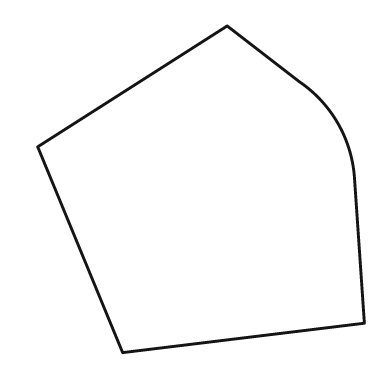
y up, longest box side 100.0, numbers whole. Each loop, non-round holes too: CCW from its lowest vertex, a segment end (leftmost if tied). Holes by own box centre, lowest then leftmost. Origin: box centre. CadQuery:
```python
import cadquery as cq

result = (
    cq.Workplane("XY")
    .moveTo(-24.0, -50.0)
    .lineTo(50.0, -41.0)
    .lineTo(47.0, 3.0)
    .threePointArc((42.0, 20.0), (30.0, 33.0))
    .lineTo(8.0, 50.0)
    .lineTo(-50.0, 13.0)
    .close()
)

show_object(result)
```